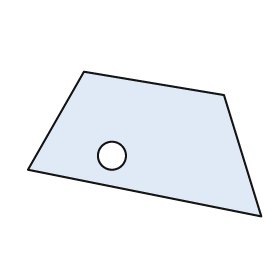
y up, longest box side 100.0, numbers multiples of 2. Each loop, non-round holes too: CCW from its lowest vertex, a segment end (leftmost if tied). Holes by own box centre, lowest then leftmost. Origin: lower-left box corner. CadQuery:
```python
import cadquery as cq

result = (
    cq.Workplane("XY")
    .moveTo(100.0, 0.0)
    .lineTo(84.0, 52.0)
    .lineTo(24.0, 62.0)
    .lineTo(0.0, 20.0)
    .close()
    .moveTo(36.0, 26.0)
    .circle(6.0)
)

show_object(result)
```